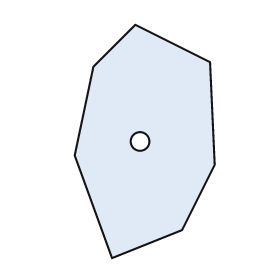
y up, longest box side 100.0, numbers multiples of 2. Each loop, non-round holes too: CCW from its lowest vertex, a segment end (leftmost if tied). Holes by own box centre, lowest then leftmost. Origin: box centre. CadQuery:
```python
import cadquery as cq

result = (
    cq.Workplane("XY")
    .moveTo(-14.0, -50.0)
    .lineTo(16.0, -38.0)
    .lineTo(30.0, -10.0)
    .lineTo(28.0, 34.0)
    .lineTo(-4.0, 50.0)
    .lineTo(-22.0, 32.0)
    .lineTo(-30.0, -6.0)
    .close()
    .moveTo(-2.0, 0.0)
    .circle(4.0)
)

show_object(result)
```